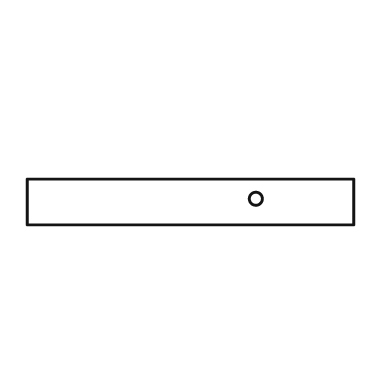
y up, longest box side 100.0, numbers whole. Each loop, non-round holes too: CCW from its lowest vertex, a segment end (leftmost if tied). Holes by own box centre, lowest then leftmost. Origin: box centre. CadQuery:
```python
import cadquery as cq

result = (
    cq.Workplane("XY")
    .moveTo(-50.0, -7.0)
    .lineTo(50.0, -7.0)
    .lineTo(50.0, 7.0)
    .lineTo(-50.0, 7.0)
    .close()
    .moveTo(20.0, 1.0)
    .circle(2.0)
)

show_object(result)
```